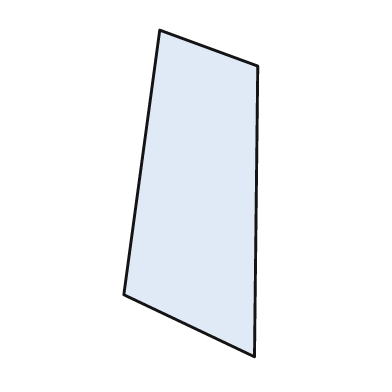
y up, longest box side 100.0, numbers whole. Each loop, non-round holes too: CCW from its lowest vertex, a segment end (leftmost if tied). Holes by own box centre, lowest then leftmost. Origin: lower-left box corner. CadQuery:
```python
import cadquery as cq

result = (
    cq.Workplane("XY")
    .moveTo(40.0, 0.0)
    .lineTo(41.0, 89.0)
    .lineTo(11.0, 100.0)
    .lineTo(0.0, 19.0)
    .close()
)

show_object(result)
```